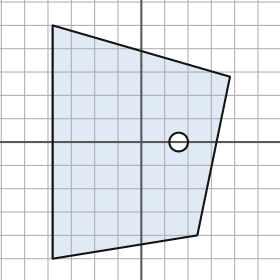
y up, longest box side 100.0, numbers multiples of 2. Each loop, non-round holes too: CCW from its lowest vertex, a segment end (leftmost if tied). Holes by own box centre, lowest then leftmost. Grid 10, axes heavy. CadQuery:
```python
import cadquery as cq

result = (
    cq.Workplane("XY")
    .moveTo(-38.0, -50.0)
    .lineTo(24.0, -40.0)
    .lineTo(38.0, 28.0)
    .lineTo(-38.0, 50.0)
    .close()
    .moveTo(16.0, 0.0)
    .circle(4.0)
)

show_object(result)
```